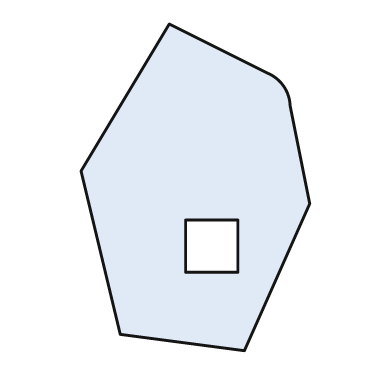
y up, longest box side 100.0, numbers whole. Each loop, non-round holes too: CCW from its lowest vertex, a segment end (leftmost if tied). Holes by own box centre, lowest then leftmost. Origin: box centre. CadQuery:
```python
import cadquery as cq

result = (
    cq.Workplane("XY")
    .moveTo(15.0, -50.0)
    .lineTo(35.0, -5.0)
    .lineTo(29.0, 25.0)
    .threePointArc((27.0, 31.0), (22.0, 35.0))
    .lineTo(-8.0, 50.0)
    .lineTo(-35.0, 5.0)
    .lineTo(-23.0, -45.0)
    .close()
    .moveTo(-3.0, -26.0)
    .lineTo(13.0, -26.0)
    .lineTo(13.0, -10.0)
    .lineTo(-3.0, -10.0)
    .close()
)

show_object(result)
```